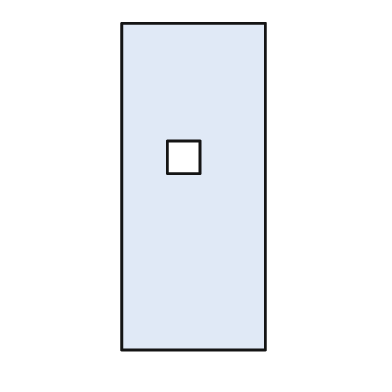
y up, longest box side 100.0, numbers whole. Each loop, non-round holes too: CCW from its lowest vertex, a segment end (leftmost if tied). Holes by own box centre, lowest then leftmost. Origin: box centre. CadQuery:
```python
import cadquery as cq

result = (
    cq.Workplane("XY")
    .moveTo(-22.0, -50.0)
    .lineTo(22.0, -50.0)
    .lineTo(22.0, 50.0)
    .lineTo(-22.0, 50.0)
    .close()
    .moveTo(-8.0, 4.0)
    .lineTo(2.0, 4.0)
    .lineTo(2.0, 14.0)
    .lineTo(-8.0, 14.0)
    .close()
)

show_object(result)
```